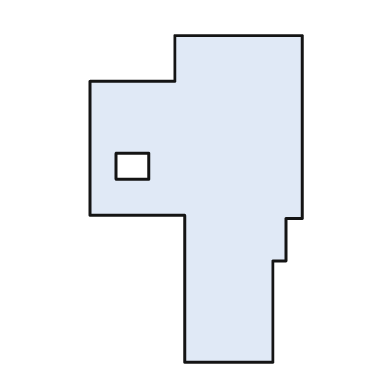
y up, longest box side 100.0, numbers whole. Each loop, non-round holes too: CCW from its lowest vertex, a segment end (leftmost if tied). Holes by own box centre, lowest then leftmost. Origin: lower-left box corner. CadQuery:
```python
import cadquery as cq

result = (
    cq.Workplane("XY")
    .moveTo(29.0, 0.0)
    .lineTo(56.0, 0.0)
    .lineTo(56.0, 31.0)
    .lineTo(60.0, 31.0)
    .lineTo(60.0, 44.0)
    .lineTo(65.0, 44.0)
    .lineTo(65.0, 100.0)
    .lineTo(26.0, 100.0)
    .lineTo(26.0, 86.0)
    .lineTo(0.0, 86.0)
    .lineTo(0.0, 45.0)
    .lineTo(29.0, 45.0)
    .close()
    .moveTo(8.0, 56.0)
    .lineTo(18.0, 56.0)
    .lineTo(18.0, 64.0)
    .lineTo(8.0, 64.0)
    .close()
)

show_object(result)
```